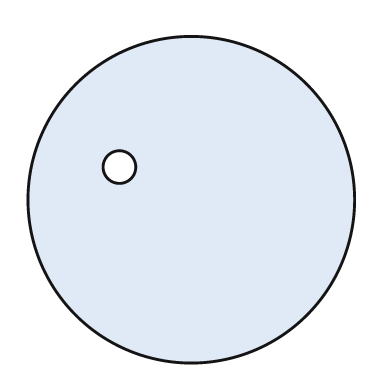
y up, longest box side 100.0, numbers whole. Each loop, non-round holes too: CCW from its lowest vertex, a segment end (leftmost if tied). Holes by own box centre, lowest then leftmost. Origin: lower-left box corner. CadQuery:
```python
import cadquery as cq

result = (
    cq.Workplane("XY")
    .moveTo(50.0, 50.0)
    .circle(50.0)
    .moveTo(28.0, 60.0)
    .circle(5.0)
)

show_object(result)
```